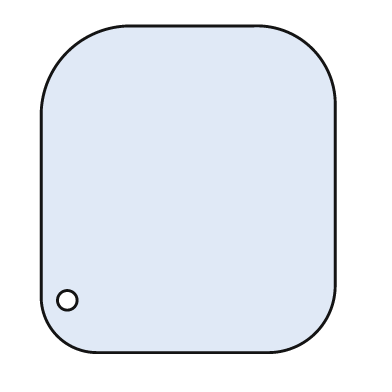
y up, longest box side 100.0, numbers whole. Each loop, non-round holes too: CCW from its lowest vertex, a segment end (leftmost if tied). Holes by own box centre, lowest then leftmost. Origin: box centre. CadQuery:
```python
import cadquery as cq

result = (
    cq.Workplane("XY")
    .moveTo(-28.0, -50.0)
    .lineTo(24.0, -50.0)
    .threePointArc((39.0, -44.0), (45.0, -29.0))
    .lineTo(45.0, 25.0)
    .threePointArc((38.0, 43.0), (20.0, 50.0))
    .lineTo(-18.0, 50.0)
    .threePointArc((-37.0, 42.0), (-45.0, 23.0))
    .lineTo(-45.0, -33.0)
    .threePointArc((-40.0, -45.0), (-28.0, -50.0))
    .close()
    .moveTo(-37.0, -34.0)
    .circle(3.0)
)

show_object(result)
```